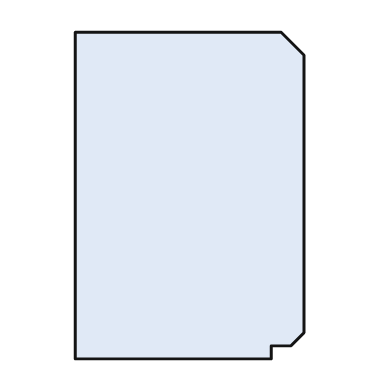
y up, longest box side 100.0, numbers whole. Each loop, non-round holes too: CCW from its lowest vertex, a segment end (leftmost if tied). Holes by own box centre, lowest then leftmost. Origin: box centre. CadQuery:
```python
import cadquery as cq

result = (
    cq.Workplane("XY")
    .moveTo(-35.0, -50.0)
    .lineTo(25.0, -50.0)
    .lineTo(25.0, -46.0)
    .lineTo(31.0, -46.0)
    .lineTo(35.0, -42.0)
    .lineTo(35.0, 43.0)
    .lineTo(28.0, 50.0)
    .lineTo(-35.0, 50.0)
    .close()
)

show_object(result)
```